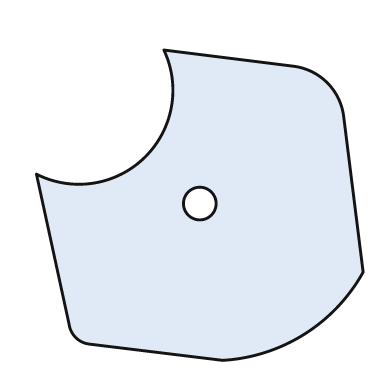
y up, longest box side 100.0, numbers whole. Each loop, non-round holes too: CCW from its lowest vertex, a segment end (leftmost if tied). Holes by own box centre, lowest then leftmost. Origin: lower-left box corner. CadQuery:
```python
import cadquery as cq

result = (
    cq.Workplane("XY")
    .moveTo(57.0, 0.0)
    .threePointArc((82.0, 8.0), (100.0, 27.0))
    .lineTo(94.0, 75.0)
    .threePointArc((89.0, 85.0), (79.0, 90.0))
    .lineTo(39.0, 95.0)
    .threePointArc((33.0, 62.0), (0.0, 57.0))
    .lineTo(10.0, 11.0)
    .threePointArc((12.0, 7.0), (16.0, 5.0))
    .close()
    .moveTo(50.0, 48.0)
    .circle(5.0)
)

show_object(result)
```